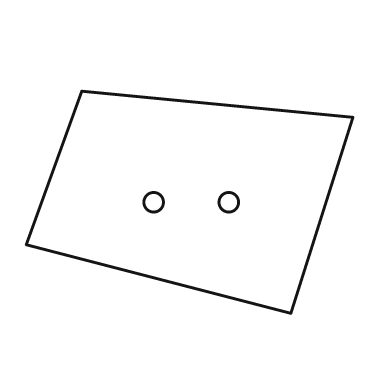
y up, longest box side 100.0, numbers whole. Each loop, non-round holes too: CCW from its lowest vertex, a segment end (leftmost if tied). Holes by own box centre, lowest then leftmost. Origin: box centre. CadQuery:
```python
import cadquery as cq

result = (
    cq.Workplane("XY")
    .moveTo(31.0, -34.0)
    .lineTo(50.0, 26.0)
    .lineTo(-33.0, 34.0)
    .lineTo(-50.0, -13.0)
    .close()
    .moveTo(-11.0, 0.0)
    .circle(3.0)
    .moveTo(12.0, 0.0)
    .circle(3.0)
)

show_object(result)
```